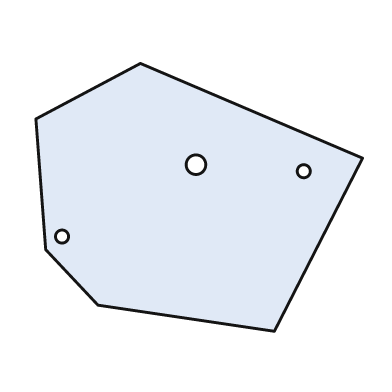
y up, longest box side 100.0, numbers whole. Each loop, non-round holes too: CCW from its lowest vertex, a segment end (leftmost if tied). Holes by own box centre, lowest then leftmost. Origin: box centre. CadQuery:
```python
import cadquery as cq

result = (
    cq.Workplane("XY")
    .moveTo(23.0, -41.0)
    .lineTo(50.0, 12.0)
    .lineTo(-18.0, 41.0)
    .lineTo(-50.0, 24.0)
    .lineTo(-47.0, -16.0)
    .lineTo(-31.0, -33.0)
    .close()
    .moveTo(-42.0, -12.0)
    .circle(2.0)
    .moveTo(32.0, 8.0)
    .circle(2.0)
    .moveTo(-1.0, 10.0)
    .circle(3.0)
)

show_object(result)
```